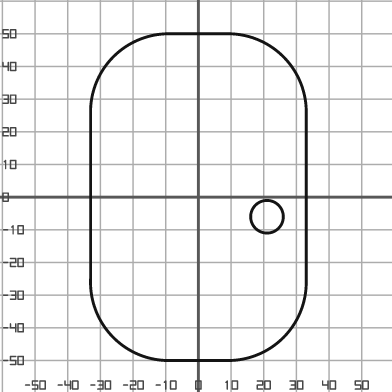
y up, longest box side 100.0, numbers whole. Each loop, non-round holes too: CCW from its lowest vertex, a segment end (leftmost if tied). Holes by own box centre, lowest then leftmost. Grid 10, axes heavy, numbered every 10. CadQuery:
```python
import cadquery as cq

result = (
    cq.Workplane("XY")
    .moveTo(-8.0, -50.0)
    .lineTo(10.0, -50.0)
    .threePointArc((26.0, -43.0), (33.0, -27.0))
    .lineTo(33.0, 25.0)
    .threePointArc((26.0, 43.0), (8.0, 50.0))
    .lineTo(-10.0, 50.0)
    .threePointArc((-26.0, 43.0), (-33.0, 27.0))
    .lineTo(-33.0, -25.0)
    .threePointArc((-26.0, -43.0), (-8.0, -50.0))
    .close()
    .moveTo(21.0, -6.0)
    .circle(5.0)
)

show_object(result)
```